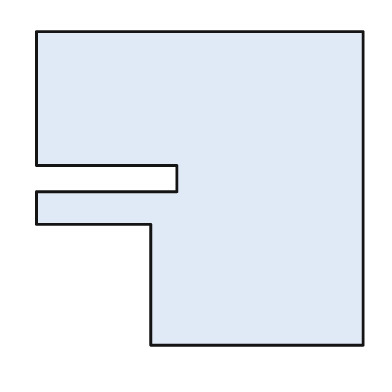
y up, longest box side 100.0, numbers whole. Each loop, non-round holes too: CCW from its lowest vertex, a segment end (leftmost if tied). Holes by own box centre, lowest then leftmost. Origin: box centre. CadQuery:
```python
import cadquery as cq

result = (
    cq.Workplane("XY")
    .moveTo(-15.0, -48.0)
    .lineTo(50.0, -48.0)
    .lineTo(50.0, 48.0)
    .lineTo(-50.0, 48.0)
    .lineTo(-50.0, 7.0)
    .lineTo(-7.0, 7.0)
    .lineTo(-7.0, -1.0)
    .lineTo(-50.0, -1.0)
    .lineTo(-50.0, -11.0)
    .lineTo(-15.0, -11.0)
    .close()
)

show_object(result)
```